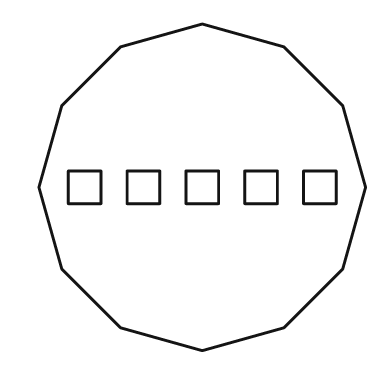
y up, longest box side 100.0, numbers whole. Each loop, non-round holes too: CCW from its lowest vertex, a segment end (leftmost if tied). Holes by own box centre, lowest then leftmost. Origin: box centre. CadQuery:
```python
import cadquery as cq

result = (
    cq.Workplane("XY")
    .moveTo(0.0, -50.0)
    .lineTo(25.0, -43.0)
    .lineTo(43.0, -25.0)
    .lineTo(50.0, 0.0)
    .lineTo(43.0, 25.0)
    .lineTo(25.0, 43.0)
    .lineTo(0.0, 50.0)
    .lineTo(-25.0, 43.0)
    .lineTo(-43.0, 25.0)
    .lineTo(-50.0, 0.0)
    .lineTo(-43.0, -25.0)
    .lineTo(-25.0, -43.0)
    .close()
    .moveTo(-41.0, -5.0)
    .lineTo(-31.0, -5.0)
    .lineTo(-31.0, 5.0)
    .lineTo(-41.0, 5.0)
    .close()
    .moveTo(-23.0, -5.0)
    .lineTo(-13.0, -5.0)
    .lineTo(-13.0, 5.0)
    .lineTo(-23.0, 5.0)
    .close()
    .moveTo(-5.0, -5.0)
    .lineTo(5.0, -5.0)
    .lineTo(5.0, 5.0)
    .lineTo(-5.0, 5.0)
    .close()
    .moveTo(13.0, -5.0)
    .lineTo(23.0, -5.0)
    .lineTo(23.0, 5.0)
    .lineTo(13.0, 5.0)
    .close()
    .moveTo(31.0, -5.0)
    .lineTo(41.0, -5.0)
    .lineTo(41.0, 5.0)
    .lineTo(31.0, 5.0)
    .close()
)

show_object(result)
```